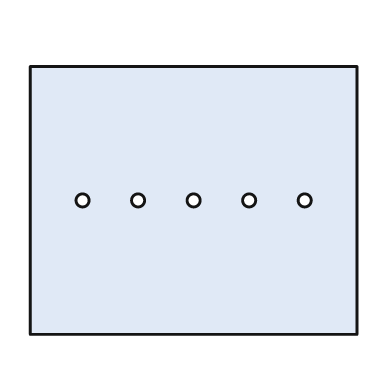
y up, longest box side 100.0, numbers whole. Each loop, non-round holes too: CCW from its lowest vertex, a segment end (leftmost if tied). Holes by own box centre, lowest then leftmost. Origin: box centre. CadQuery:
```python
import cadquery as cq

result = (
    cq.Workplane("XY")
    .moveTo(-50.0, -41.0)
    .lineTo(50.0, -41.0)
    .lineTo(50.0, 41.0)
    .lineTo(-50.0, 41.0)
    .close()
    .moveTo(-34.0, 0.0)
    .circle(2.0)
    .moveTo(-17.0, 0.0)
    .circle(2.0)
    .moveTo(0.0, 0.0)
    .circle(2.0)
    .moveTo(17.0, 0.0)
    .circle(2.0)
    .moveTo(34.0, 0.0)
    .circle(2.0)
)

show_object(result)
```